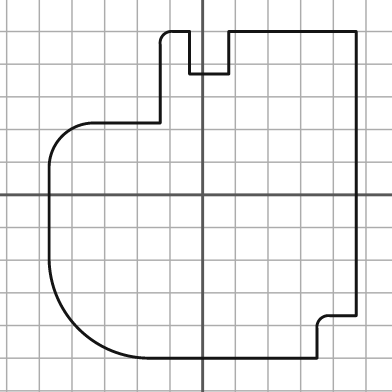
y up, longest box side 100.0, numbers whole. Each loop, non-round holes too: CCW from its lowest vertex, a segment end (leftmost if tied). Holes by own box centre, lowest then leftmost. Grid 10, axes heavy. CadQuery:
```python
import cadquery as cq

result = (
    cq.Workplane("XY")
    .moveTo(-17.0, -50.0)
    .lineTo(35.0, -50.0)
    .lineTo(35.0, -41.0)
    .threePointArc((36.0, -38.0), (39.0, -37.0))
    .lineTo(47.0, -37.0)
    .lineTo(47.0, 50.0)
    .lineTo(8.0, 50.0)
    .lineTo(8.0, 37.0)
    .lineTo(-4.0, 37.0)
    .lineTo(-4.0, 50.0)
    .lineTo(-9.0, 50.0)
    .threePointArc((-12.0, 49.0), (-13.0, 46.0))
    .lineTo(-13.0, 22.0)
    .lineTo(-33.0, 22.0)
    .threePointArc((-43.0, 18.0), (-47.0, 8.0))
    .lineTo(-47.0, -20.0)
    .threePointArc((-38.0, -41.0), (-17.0, -50.0))
    .close()
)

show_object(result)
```